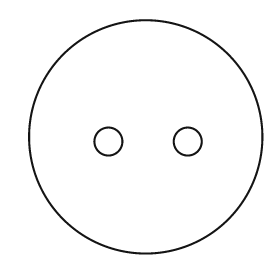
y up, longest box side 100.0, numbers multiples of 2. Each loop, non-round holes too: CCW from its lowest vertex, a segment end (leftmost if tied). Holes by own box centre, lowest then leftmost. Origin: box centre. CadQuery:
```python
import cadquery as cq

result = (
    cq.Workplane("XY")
    .moveTo(0.0, 0.0)
    .circle(50.0)
    .moveTo(-16.0, -2.0)
    .circle(6.0)
    .moveTo(18.0, -2.0)
    .circle(6.0)
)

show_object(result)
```